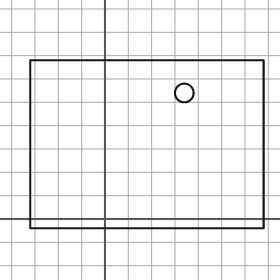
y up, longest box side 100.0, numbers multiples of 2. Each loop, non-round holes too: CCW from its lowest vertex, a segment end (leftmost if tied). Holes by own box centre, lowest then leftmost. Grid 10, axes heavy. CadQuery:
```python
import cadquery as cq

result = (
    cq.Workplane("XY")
    .moveTo(-32.0, -4.0)
    .lineTo(68.0, -4.0)
    .lineTo(68.0, 68.0)
    .lineTo(-32.0, 68.0)
    .close()
    .moveTo(34.0, 54.0)
    .circle(4.0)
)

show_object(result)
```